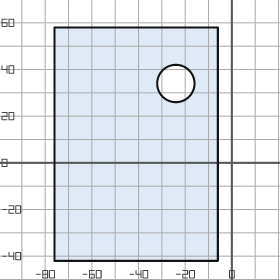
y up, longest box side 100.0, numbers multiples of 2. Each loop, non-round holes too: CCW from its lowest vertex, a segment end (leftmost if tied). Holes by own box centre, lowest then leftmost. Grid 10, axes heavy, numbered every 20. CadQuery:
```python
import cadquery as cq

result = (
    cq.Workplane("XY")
    .moveTo(-76.0, -42.0)
    .lineTo(-6.0, -42.0)
    .lineTo(-6.0, 58.0)
    .lineTo(-76.0, 58.0)
    .close()
    .moveTo(-24.0, 34.0)
    .circle(8.0)
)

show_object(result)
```